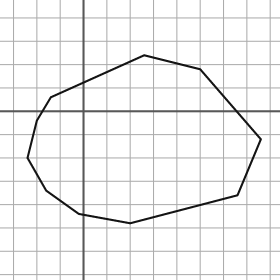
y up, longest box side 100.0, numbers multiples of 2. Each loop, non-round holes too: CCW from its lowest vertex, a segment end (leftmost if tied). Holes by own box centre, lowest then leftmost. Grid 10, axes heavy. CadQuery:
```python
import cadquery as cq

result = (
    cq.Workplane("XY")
    .moveTo(20.0, -48.0)
    .lineTo(66.0, -36.0)
    .lineTo(76.0, -12.0)
    .lineTo(50.0, 18.0)
    .lineTo(26.0, 24.0)
    .lineTo(-14.0, 6.0)
    .lineTo(-20.0, -4.0)
    .lineTo(-24.0, -20.0)
    .lineTo(-16.0, -34.0)
    .lineTo(-2.0, -44.0)
    .close()
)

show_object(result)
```